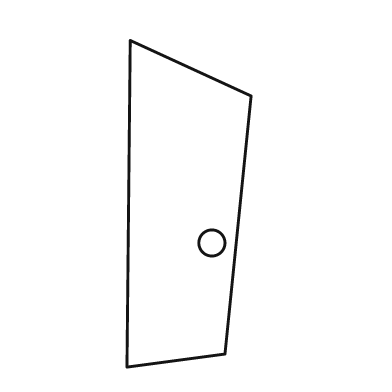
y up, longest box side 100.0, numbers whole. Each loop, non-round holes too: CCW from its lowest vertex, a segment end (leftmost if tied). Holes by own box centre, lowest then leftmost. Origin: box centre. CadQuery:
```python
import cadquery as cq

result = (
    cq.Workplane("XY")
    .moveTo(-19.0, -50.0)
    .lineTo(11.0, -46.0)
    .lineTo(19.0, 33.0)
    .lineTo(-18.0, 50.0)
    .close()
    .moveTo(7.0, -12.0)
    .circle(4.0)
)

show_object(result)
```